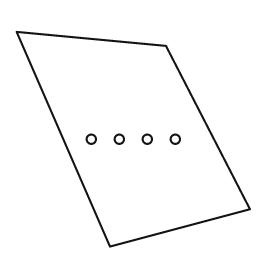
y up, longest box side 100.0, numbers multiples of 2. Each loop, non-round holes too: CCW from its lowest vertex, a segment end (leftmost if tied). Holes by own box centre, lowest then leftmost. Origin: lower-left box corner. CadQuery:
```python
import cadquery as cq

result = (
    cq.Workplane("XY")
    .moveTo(40.0, 0.0)
    .lineTo(100.0, 16.0)
    .lineTo(64.0, 86.0)
    .lineTo(0.0, 92.0)
    .close()
    .moveTo(32.0, 46.0)
    .circle(2.0)
    .moveTo(44.0, 46.0)
    .circle(2.0)
    .moveTo(56.0, 46.0)
    .circle(2.0)
    .moveTo(68.0, 46.0)
    .circle(2.0)
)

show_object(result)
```